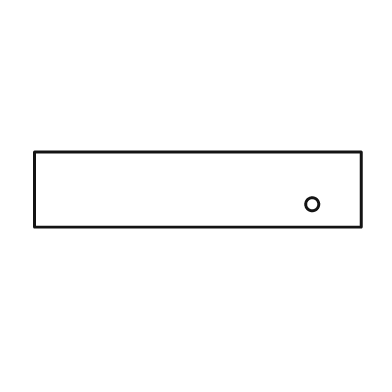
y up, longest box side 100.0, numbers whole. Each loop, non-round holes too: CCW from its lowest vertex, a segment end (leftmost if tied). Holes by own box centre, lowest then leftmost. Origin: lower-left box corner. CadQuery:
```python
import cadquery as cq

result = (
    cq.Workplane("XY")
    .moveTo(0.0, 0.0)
    .lineTo(100.0, 0.0)
    .lineTo(100.0, 23.0)
    .lineTo(0.0, 23.0)
    .close()
    .moveTo(85.0, 7.0)
    .circle(2.0)
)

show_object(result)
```